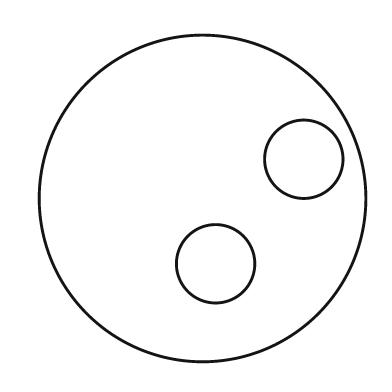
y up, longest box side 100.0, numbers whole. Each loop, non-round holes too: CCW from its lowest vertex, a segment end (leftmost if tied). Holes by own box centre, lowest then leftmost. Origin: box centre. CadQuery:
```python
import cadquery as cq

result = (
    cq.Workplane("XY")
    .moveTo(0.0, 0.0)
    .circle(50.0)
    .moveTo(4.0, -20.0)
    .circle(12.0)
    .moveTo(31.0, 12.0)
    .circle(12.0)
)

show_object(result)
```